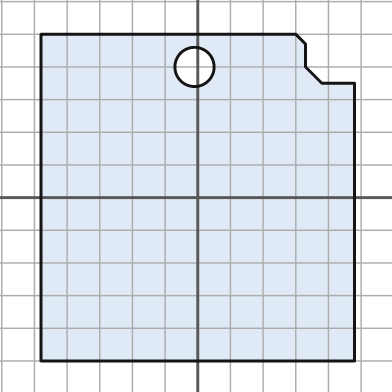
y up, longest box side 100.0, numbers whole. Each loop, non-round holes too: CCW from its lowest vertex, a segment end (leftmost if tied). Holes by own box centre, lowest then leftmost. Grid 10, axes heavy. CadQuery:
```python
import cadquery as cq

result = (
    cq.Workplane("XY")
    .moveTo(-48.0, -50.0)
    .lineTo(48.0, -50.0)
    .lineTo(48.0, 35.0)
    .lineTo(38.0, 35.0)
    .lineTo(33.0, 40.0)
    .lineTo(33.0, 47.0)
    .lineTo(30.0, 50.0)
    .lineTo(-48.0, 50.0)
    .close()
    .moveTo(-1.0, 40.0)
    .circle(6.0)
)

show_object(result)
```